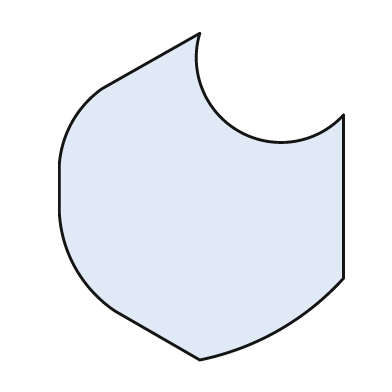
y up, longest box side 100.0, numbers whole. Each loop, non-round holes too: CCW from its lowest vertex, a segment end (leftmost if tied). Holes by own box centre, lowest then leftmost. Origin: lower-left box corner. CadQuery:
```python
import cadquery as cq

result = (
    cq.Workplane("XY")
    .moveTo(43.0, 0.0)
    .threePointArc((67.0, 9.0), (87.0, 25.0))
    .lineTo(87.0, 75.0)
    .threePointArc((55.0, 70.0), (43.0, 100.0))
    .lineTo(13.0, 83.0)
    .threePointArc((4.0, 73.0), (0.0, 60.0))
    .lineTo(0.0, 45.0)
    .threePointArc((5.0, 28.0), (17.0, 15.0))
    .close()
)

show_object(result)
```